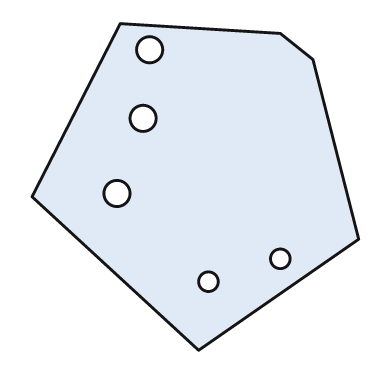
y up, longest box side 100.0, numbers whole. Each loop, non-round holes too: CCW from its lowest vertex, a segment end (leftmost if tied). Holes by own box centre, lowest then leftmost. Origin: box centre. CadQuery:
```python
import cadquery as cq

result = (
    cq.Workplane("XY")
    .moveTo(1.0, -50.0)
    .lineTo(50.0, -16.0)
    .lineTo(36.0, 39.0)
    .lineTo(26.0, 47.0)
    .lineTo(-23.0, 50.0)
    .lineTo(-50.0, -3.0)
    .close()
    .moveTo(4.0, -29.0)
    .circle(3.0)
    .moveTo(26.0, -22.0)
    .circle(3.0)
    .moveTo(-24.0, -2.0)
    .circle(4.0)
    .moveTo(-16.0, 21.0)
    .circle(4.0)
    .moveTo(-14.0, 42.0)
    .circle(4.0)
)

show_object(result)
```